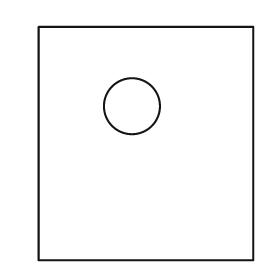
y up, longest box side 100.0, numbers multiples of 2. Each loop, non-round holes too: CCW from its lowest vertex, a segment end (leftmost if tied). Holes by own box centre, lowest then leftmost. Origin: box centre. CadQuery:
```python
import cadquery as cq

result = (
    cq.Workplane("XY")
    .moveTo(-46.0, -50.0)
    .lineTo(46.0, -50.0)
    .lineTo(46.0, 50.0)
    .lineTo(-46.0, 50.0)
    .close()
    .moveTo(-6.0, 16.0)
    .circle(12.0)
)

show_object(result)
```